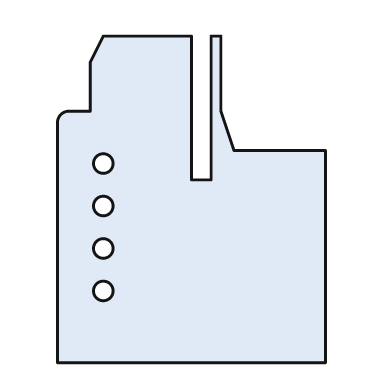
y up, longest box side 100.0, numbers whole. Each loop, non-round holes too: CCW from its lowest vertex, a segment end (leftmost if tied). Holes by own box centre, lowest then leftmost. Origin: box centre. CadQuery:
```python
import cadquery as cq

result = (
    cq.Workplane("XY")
    .moveTo(-41.0, -50.0)
    .lineTo(41.0, -50.0)
    .lineTo(41.0, 15.0)
    .lineTo(13.0, 15.0)
    .lineTo(9.0, 27.0)
    .lineTo(9.0, 50.0)
    .lineTo(6.0, 50.0)
    .lineTo(6.0, 6.0)
    .lineTo(0.0, 6.0)
    .lineTo(0.0, 50.0)
    .lineTo(-27.0, 50.0)
    .lineTo(-31.0, 42.0)
    .lineTo(-31.0, 27.0)
    .lineTo(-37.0, 27.0)
    .threePointArc((-40.0, 26.0), (-41.0, 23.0))
    .close()
    .moveTo(-27.0, -28.0)
    .circle(3.0)
    .moveTo(-27.0, -15.0)
    .circle(3.0)
    .moveTo(-27.0, -2.0)
    .circle(3.0)
    .moveTo(-27.0, 11.0)
    .circle(3.0)
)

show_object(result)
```